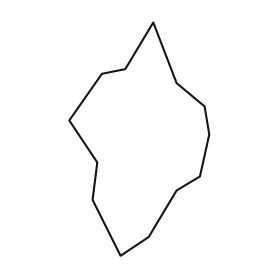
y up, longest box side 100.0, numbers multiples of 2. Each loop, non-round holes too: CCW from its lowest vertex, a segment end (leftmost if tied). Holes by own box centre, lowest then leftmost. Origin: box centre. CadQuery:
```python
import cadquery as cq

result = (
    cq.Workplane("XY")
    .moveTo(-8.0, -50.0)
    .lineTo(4.0, -42.0)
    .lineTo(16.0, -22.0)
    .lineTo(26.0, -16.0)
    .lineTo(30.0, 2.0)
    .lineTo(28.0, 14.0)
    .lineTo(16.0, 24.0)
    .lineTo(6.0, 50.0)
    .lineTo(-6.0, 30.0)
    .lineTo(-16.0, 28.0)
    .lineTo(-30.0, 8.0)
    .lineTo(-18.0, -10.0)
    .lineTo(-20.0, -26.0)
    .close()
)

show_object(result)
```